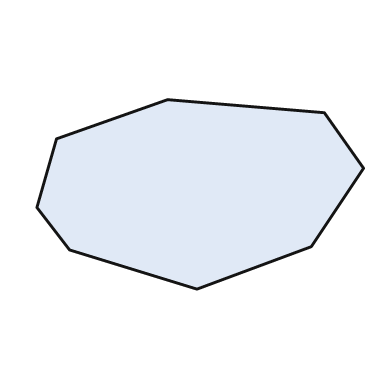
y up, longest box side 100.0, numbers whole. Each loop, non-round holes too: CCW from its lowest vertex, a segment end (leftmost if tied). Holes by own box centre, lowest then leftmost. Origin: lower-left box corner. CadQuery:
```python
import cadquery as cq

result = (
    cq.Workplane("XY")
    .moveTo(49.0, 0.0)
    .lineTo(84.0, 13.0)
    .lineTo(100.0, 37.0)
    .lineTo(88.0, 54.0)
    .lineTo(40.0, 58.0)
    .lineTo(6.0, 46.0)
    .lineTo(0.0, 25.0)
    .lineTo(10.0, 12.0)
    .close()
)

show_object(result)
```